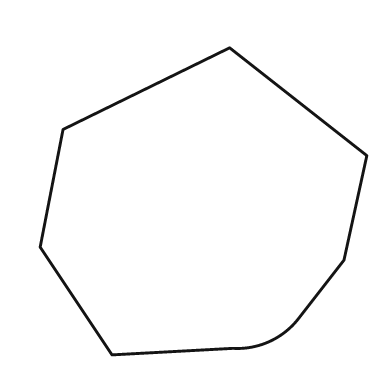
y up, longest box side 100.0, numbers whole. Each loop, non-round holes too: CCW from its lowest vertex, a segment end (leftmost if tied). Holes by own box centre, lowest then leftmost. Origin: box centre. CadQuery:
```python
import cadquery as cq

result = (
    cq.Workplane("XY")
    .moveTo(-28.0, -47.0)
    .lineTo(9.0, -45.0)
    .threePointArc((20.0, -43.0), (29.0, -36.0))
    .lineTo(43.0, -18.0)
    .lineTo(50.0, 14.0)
    .lineTo(8.0, 47.0)
    .lineTo(-43.0, 22.0)
    .lineTo(-50.0, -14.0)
    .close()
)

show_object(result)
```